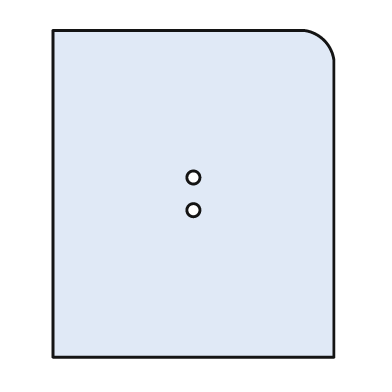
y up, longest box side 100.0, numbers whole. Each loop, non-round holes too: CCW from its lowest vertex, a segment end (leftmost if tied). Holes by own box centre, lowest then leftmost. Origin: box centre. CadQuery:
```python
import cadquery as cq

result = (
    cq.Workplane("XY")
    .moveTo(-43.0, -50.0)
    .lineTo(43.0, -50.0)
    .lineTo(43.0, 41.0)
    .threePointArc((40.0, 47.0), (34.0, 50.0))
    .lineTo(-43.0, 50.0)
    .close()
    .moveTo(0.0, -5.0)
    .circle(2.0)
    .moveTo(0.0, 5.0)
    .circle(2.0)
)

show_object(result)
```